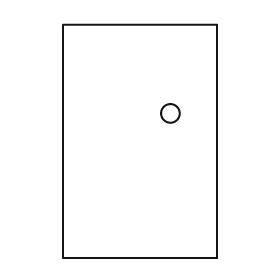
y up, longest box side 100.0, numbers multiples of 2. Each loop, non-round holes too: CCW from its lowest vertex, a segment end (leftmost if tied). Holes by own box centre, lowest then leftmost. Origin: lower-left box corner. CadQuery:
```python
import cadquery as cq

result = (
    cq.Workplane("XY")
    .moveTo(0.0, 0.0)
    .lineTo(66.0, 0.0)
    .lineTo(66.0, 100.0)
    .lineTo(0.0, 100.0)
    .close()
    .moveTo(46.0, 62.0)
    .circle(4.0)
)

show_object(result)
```